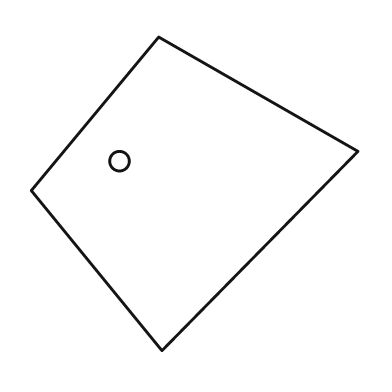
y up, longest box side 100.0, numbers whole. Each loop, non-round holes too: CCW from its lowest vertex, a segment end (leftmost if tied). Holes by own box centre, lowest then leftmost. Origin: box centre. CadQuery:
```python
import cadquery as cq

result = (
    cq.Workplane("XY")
    .moveTo(-10.0, -48.0)
    .lineTo(50.0, 13.0)
    .lineTo(-11.0, 48.0)
    .lineTo(-50.0, 1.0)
    .close()
    .moveTo(-23.0, 10.0)
    .circle(3.0)
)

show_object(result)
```